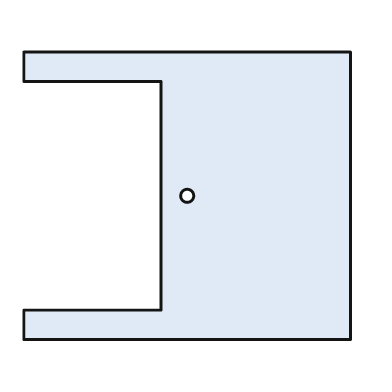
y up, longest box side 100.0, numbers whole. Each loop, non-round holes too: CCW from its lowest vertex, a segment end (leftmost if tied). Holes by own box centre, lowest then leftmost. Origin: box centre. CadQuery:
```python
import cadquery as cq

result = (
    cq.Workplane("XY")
    .moveTo(-50.0, -44.0)
    .lineTo(50.0, -44.0)
    .lineTo(50.0, 44.0)
    .lineTo(-50.0, 44.0)
    .lineTo(-50.0, 35.0)
    .lineTo(-8.0, 35.0)
    .lineTo(-8.0, -35.0)
    .lineTo(-50.0, -35.0)
    .close()
    .moveTo(0.0, 0.0)
    .circle(2.0)
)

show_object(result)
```